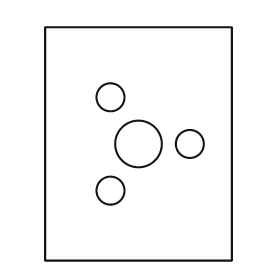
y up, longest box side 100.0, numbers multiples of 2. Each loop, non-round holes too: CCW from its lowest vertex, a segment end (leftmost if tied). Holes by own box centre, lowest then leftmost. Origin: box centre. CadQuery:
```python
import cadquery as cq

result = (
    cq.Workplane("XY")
    .moveTo(-40.0, -50.0)
    .lineTo(40.0, -50.0)
    .lineTo(40.0, 50.0)
    .lineTo(-40.0, 50.0)
    .close()
    .moveTo(-12.0, -20.0)
    .circle(6.0)
    .moveTo(0.0, 0.0)
    .circle(10.0)
    .moveTo(22.0, 0.0)
    .circle(6.0)
    .moveTo(-12.0, 20.0)
    .circle(6.0)
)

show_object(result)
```